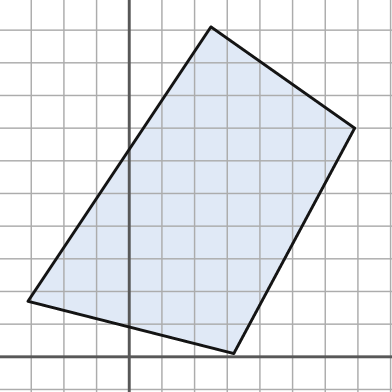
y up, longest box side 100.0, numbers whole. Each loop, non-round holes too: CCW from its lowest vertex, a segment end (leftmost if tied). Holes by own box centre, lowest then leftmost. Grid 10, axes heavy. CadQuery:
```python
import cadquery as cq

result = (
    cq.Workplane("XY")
    .moveTo(32.0, 1.0)
    .lineTo(69.0, 70.0)
    .lineTo(25.0, 101.0)
    .lineTo(-31.0, 17.0)
    .close()
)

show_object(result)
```